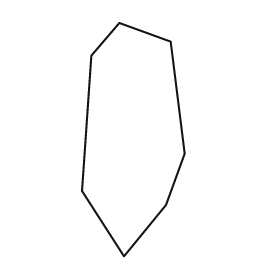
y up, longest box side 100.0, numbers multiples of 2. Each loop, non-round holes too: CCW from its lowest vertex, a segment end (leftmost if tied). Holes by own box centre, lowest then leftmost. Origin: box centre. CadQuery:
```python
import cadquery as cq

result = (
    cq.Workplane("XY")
    .moveTo(-4.0, -50.0)
    .lineTo(14.0, -28.0)
    .lineTo(22.0, -6.0)
    .lineTo(16.0, 42.0)
    .lineTo(-6.0, 50.0)
    .lineTo(-18.0, 36.0)
    .lineTo(-22.0, -22.0)
    .close()
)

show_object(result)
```